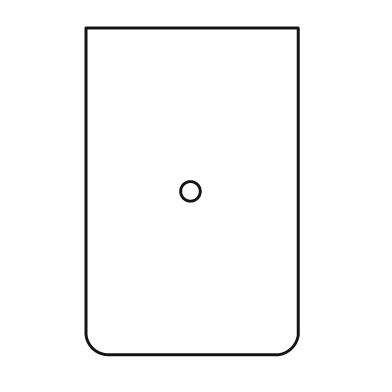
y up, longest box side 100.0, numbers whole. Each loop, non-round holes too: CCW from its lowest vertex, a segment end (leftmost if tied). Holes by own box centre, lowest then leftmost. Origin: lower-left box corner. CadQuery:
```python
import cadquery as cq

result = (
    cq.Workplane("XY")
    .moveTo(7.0, 0.0)
    .lineTo(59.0, 0.0)
    .threePointArc((63.0, 2.0), (65.0, 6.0))
    .lineTo(65.0, 100.0)
    .lineTo(0.0, 100.0)
    .lineTo(0.0, 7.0)
    .threePointArc((2.0, 2.0), (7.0, 0.0))
    .close()
    .moveTo(32.0, 50.0)
    .circle(3.0)
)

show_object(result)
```